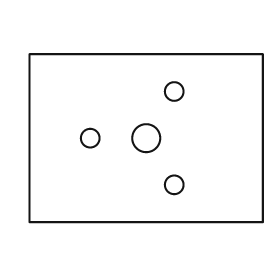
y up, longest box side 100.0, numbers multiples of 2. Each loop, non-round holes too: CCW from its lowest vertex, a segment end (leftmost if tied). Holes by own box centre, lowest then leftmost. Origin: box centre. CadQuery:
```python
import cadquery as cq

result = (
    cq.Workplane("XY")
    .moveTo(-50.0, -36.0)
    .lineTo(50.0, -36.0)
    .lineTo(50.0, 36.0)
    .lineTo(-50.0, 36.0)
    .close()
    .moveTo(12.0, -20.0)
    .circle(4.0)
    .moveTo(-24.0, 0.0)
    .circle(4.0)
    .moveTo(0.0, 0.0)
    .circle(6.0)
    .moveTo(12.0, 20.0)
    .circle(4.0)
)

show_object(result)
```